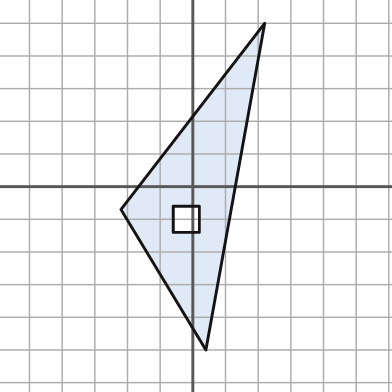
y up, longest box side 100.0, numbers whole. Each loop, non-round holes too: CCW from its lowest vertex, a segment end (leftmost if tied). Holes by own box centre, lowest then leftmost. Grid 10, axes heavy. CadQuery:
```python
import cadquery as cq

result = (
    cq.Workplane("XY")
    .moveTo(4.0, -50.0)
    .lineTo(22.0, 50.0)
    .lineTo(-22.0, -7.0)
    .close()
    .moveTo(-6.0, -14.0)
    .lineTo(2.0, -14.0)
    .lineTo(2.0, -6.0)
    .lineTo(-6.0, -6.0)
    .close()
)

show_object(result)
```